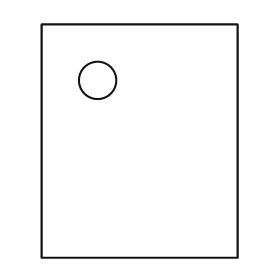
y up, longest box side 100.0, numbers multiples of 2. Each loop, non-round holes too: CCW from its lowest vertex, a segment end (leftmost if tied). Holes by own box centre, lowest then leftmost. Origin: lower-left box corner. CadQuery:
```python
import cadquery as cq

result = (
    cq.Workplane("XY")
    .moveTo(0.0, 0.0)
    .lineTo(84.0, 0.0)
    .lineTo(84.0, 100.0)
    .lineTo(0.0, 100.0)
    .close()
    .moveTo(24.0, 76.0)
    .circle(8.0)
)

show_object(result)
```